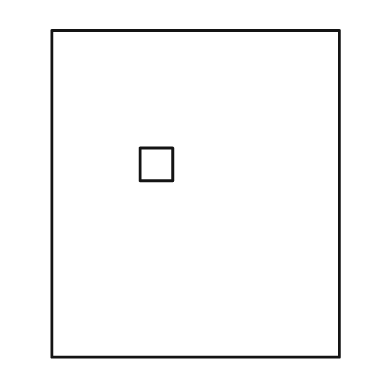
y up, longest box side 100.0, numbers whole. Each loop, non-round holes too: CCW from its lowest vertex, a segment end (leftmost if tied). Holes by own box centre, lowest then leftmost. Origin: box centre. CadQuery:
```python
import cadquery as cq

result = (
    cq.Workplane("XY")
    .moveTo(-44.0, -50.0)
    .lineTo(44.0, -50.0)
    .lineTo(44.0, 50.0)
    .lineTo(-44.0, 50.0)
    .close()
    .moveTo(-17.0, 4.0)
    .lineTo(-7.0, 4.0)
    .lineTo(-7.0, 14.0)
    .lineTo(-17.0, 14.0)
    .close()
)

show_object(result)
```